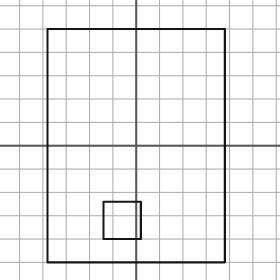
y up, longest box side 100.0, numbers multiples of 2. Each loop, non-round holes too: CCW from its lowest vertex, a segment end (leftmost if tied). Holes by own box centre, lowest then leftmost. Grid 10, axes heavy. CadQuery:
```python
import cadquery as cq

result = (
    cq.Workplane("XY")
    .moveTo(-38.0, -50.0)
    .lineTo(38.0, -50.0)
    .lineTo(38.0, 50.0)
    .lineTo(-38.0, 50.0)
    .close()
    .moveTo(-14.0, -40.0)
    .lineTo(2.0, -40.0)
    .lineTo(2.0, -24.0)
    .lineTo(-14.0, -24.0)
    .close()
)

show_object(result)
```